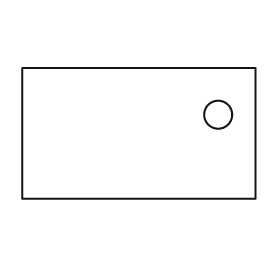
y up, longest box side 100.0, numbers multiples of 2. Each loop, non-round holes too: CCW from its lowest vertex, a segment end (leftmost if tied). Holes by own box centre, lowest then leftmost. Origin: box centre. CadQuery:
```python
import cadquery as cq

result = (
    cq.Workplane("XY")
    .moveTo(-50.0, -28.0)
    .lineTo(50.0, -28.0)
    .lineTo(50.0, 28.0)
    .lineTo(-50.0, 28.0)
    .close()
    .moveTo(34.0, 8.0)
    .circle(6.0)
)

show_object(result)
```